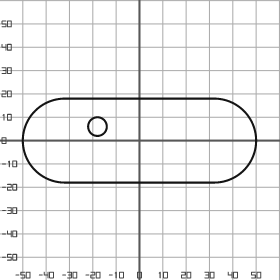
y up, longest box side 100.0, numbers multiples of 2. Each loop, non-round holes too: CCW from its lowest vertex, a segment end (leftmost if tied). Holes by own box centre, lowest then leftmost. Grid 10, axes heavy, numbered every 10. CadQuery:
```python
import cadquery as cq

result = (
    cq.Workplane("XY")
    .moveTo(-32.0, -18.0)
    .lineTo(32.0, -18.0)
    .threePointArc((50.0, 0.0), (32.0, 18.0))
    .lineTo(-32.0, 18.0)
    .threePointArc((-50.0, 0.0), (-32.0, -18.0))
    .close()
    .moveTo(-18.0, 6.0)
    .circle(4.0)
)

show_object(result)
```